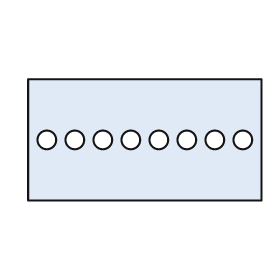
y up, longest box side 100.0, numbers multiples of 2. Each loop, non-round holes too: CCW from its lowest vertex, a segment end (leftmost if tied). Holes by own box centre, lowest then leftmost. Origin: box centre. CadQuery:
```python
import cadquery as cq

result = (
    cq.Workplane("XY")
    .moveTo(-50.0, -26.0)
    .lineTo(50.0, -26.0)
    .lineTo(50.0, 26.0)
    .lineTo(-50.0, 26.0)
    .close()
    .moveTo(-42.0, 0.0)
    .circle(4.0)
    .moveTo(-30.0, 0.0)
    .circle(4.0)
    .moveTo(-18.0, 0.0)
    .circle(4.0)
    .moveTo(-6.0, 0.0)
    .circle(4.0)
    .moveTo(6.0, 0.0)
    .circle(4.0)
    .moveTo(18.0, 0.0)
    .circle(4.0)
    .moveTo(30.0, 0.0)
    .circle(4.0)
    .moveTo(42.0, 0.0)
    .circle(4.0)
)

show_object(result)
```